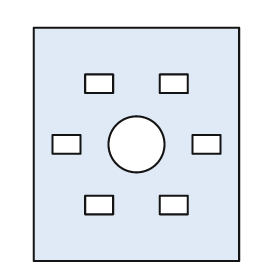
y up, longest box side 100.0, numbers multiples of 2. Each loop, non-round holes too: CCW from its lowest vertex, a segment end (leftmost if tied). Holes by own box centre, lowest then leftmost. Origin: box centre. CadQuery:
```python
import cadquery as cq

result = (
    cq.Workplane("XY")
    .moveTo(-44.0, -50.0)
    .lineTo(44.0, -50.0)
    .lineTo(44.0, 50.0)
    .lineTo(-44.0, 50.0)
    .close()
    .moveTo(-22.0, -30.0)
    .lineTo(-10.0, -30.0)
    .lineTo(-10.0, -22.0)
    .lineTo(-22.0, -22.0)
    .close()
    .moveTo(10.0, -30.0)
    .lineTo(22.0, -30.0)
    .lineTo(22.0, -22.0)
    .lineTo(10.0, -22.0)
    .close()
    .moveTo(-36.0, -4.0)
    .lineTo(-24.0, -4.0)
    .lineTo(-24.0, 4.0)
    .lineTo(-36.0, 4.0)
    .close()
    .moveTo(0.0, 0.0)
    .circle(12.0)
    .moveTo(24.0, -4.0)
    .lineTo(36.0, -4.0)
    .lineTo(36.0, 4.0)
    .lineTo(24.0, 4.0)
    .close()
    .moveTo(-22.0, 22.0)
    .lineTo(-10.0, 22.0)
    .lineTo(-10.0, 30.0)
    .lineTo(-22.0, 30.0)
    .close()
    .moveTo(10.0, 22.0)
    .lineTo(22.0, 22.0)
    .lineTo(22.0, 30.0)
    .lineTo(10.0, 30.0)
    .close()
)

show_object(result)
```